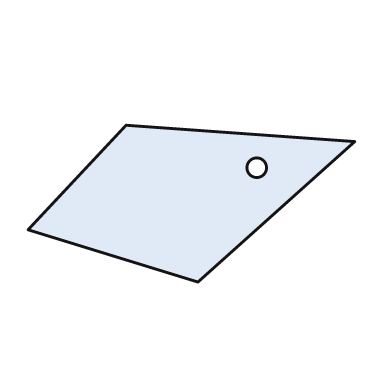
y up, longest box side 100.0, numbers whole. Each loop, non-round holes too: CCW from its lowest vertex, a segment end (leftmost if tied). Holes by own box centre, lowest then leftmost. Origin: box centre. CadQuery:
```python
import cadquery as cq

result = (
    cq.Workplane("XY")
    .moveTo(2.0, -24.0)
    .lineTo(50.0, 19.0)
    .lineTo(-20.0, 24.0)
    .lineTo(-50.0, -8.0)
    .close()
    .moveTo(20.0, 11.0)
    .circle(3.0)
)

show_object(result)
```